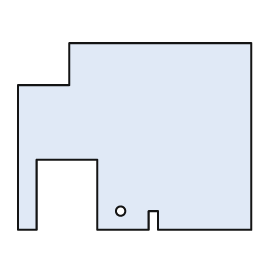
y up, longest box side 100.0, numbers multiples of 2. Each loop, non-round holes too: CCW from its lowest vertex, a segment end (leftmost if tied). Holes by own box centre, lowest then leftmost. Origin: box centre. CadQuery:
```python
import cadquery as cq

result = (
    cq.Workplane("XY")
    .moveTo(-50.0, -40.0)
    .lineTo(-42.0, -40.0)
    .lineTo(-42.0, -10.0)
    .lineTo(-16.0, -10.0)
    .lineTo(-16.0, -40.0)
    .lineTo(6.0, -40.0)
    .lineTo(6.0, -32.0)
    .lineTo(10.0, -32.0)
    .lineTo(10.0, -40.0)
    .lineTo(50.0, -40.0)
    .lineTo(50.0, 40.0)
    .lineTo(-28.0, 40.0)
    .lineTo(-28.0, 22.0)
    .lineTo(-50.0, 22.0)
    .close()
    .moveTo(-6.0, -32.0)
    .circle(2.0)
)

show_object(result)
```